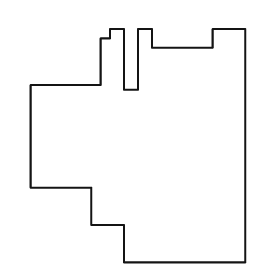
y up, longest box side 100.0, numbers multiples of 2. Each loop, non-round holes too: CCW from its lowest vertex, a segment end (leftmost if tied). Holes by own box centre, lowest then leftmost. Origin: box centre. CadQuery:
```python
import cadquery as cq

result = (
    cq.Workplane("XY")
    .moveTo(-6.0, -50.0)
    .lineTo(46.0, -50.0)
    .lineTo(46.0, 50.0)
    .lineTo(32.0, 50.0)
    .lineTo(32.0, 42.0)
    .lineTo(6.0, 42.0)
    .lineTo(6.0, 50.0)
    .lineTo(0.0, 50.0)
    .lineTo(0.0, 24.0)
    .lineTo(-6.0, 24.0)
    .lineTo(-6.0, 50.0)
    .lineTo(-12.0, 50.0)
    .lineTo(-12.0, 46.0)
    .lineTo(-16.0, 46.0)
    .lineTo(-16.0, 26.0)
    .lineTo(-46.0, 26.0)
    .lineTo(-46.0, -18.0)
    .lineTo(-20.0, -18.0)
    .lineTo(-20.0, -34.0)
    .lineTo(-6.0, -34.0)
    .close()
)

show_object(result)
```